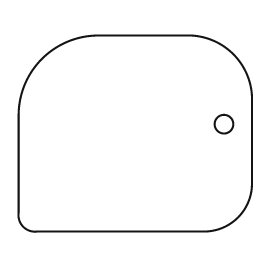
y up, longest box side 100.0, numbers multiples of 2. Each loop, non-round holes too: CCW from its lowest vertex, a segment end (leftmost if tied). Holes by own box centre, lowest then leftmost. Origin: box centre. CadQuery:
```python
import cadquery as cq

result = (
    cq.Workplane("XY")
    .moveTo(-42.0, -42.0)
    .lineTo(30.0, -42.0)
    .threePointArc((44.0, -36.0), (50.0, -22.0))
    .lineTo(50.0, 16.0)
    .threePointArc((42.0, 34.0), (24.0, 42.0))
    .lineTo(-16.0, 42.0)
    .threePointArc((-40.0, 32.0), (-50.0, 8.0))
    .lineTo(-50.0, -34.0)
    .threePointArc((-48.0, -40.0), (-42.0, -42.0))
    .close()
    .moveTo(38.0, 4.0)
    .circle(4.0)
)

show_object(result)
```